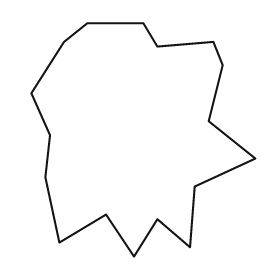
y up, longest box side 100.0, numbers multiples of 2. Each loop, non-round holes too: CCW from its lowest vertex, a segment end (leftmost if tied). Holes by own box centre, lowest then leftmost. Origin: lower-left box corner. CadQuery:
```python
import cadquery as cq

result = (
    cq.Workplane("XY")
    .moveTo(44.0, 0.0)
    .lineTo(54.0, 16.0)
    .lineTo(68.0, 4.0)
    .lineTo(70.0, 30.0)
    .lineTo(96.0, 42.0)
    .lineTo(76.0, 58.0)
    .lineTo(82.0, 82.0)
    .lineTo(78.0, 92.0)
    .lineTo(54.0, 90.0)
    .lineTo(48.0, 100.0)
    .lineTo(24.0, 100.0)
    .lineTo(14.0, 92.0)
    .lineTo(0.0, 70.0)
    .lineTo(8.0, 52.0)
    .lineTo(6.0, 34.0)
    .lineTo(12.0, 6.0)
    .lineTo(32.0, 18.0)
    .close()
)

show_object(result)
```